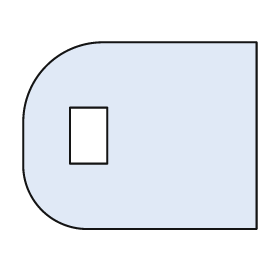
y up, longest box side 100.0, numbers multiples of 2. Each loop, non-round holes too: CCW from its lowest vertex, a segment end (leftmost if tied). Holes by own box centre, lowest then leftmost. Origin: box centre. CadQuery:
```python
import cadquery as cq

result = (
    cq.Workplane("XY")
    .moveTo(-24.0, -40.0)
    .lineTo(50.0, -40.0)
    .lineTo(50.0, 40.0)
    .lineTo(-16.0, 40.0)
    .threePointArc((-40.0, 30.0), (-50.0, 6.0))
    .lineTo(-50.0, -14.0)
    .threePointArc((-42.0, -32.0), (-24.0, -40.0))
    .close()
    .moveTo(-30.0, -12.0)
    .lineTo(-14.0, -12.0)
    .lineTo(-14.0, 12.0)
    .lineTo(-30.0, 12.0)
    .close()
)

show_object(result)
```